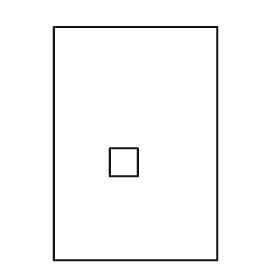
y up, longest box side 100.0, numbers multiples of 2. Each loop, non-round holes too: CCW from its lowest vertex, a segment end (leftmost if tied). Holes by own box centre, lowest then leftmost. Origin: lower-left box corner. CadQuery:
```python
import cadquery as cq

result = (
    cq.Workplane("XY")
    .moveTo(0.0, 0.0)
    .lineTo(70.0, 0.0)
    .lineTo(70.0, 100.0)
    .lineTo(0.0, 100.0)
    .close()
    .moveTo(24.0, 36.0)
    .lineTo(36.0, 36.0)
    .lineTo(36.0, 48.0)
    .lineTo(24.0, 48.0)
    .close()
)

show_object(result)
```